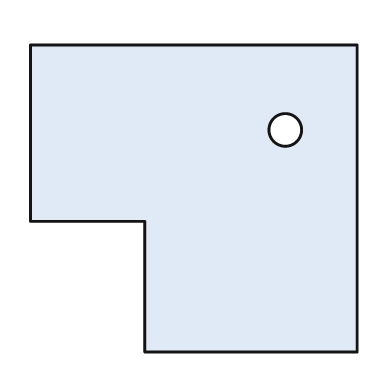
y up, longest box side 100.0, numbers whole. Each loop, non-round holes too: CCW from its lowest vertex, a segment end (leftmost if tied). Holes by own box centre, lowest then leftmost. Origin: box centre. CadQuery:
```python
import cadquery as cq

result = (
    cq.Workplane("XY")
    .moveTo(-15.0, -47.0)
    .lineTo(50.0, -47.0)
    .lineTo(50.0, 47.0)
    .lineTo(-50.0, 47.0)
    .lineTo(-50.0, -7.0)
    .lineTo(-15.0, -7.0)
    .close()
    .moveTo(28.0, 21.0)
    .circle(5.0)
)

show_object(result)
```